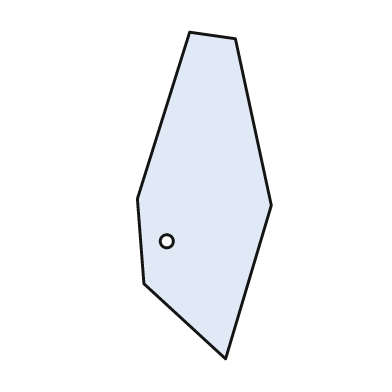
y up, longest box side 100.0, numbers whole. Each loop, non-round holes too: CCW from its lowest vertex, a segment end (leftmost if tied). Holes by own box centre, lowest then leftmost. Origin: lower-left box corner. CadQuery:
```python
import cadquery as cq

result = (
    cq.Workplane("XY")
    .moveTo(27.0, 0.0)
    .lineTo(41.0, 47.0)
    .lineTo(30.0, 98.0)
    .lineTo(16.0, 100.0)
    .lineTo(0.0, 49.0)
    .lineTo(2.0, 23.0)
    .close()
    .moveTo(9.0, 36.0)
    .circle(2.0)
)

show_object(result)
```